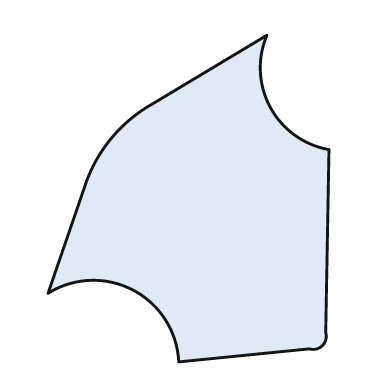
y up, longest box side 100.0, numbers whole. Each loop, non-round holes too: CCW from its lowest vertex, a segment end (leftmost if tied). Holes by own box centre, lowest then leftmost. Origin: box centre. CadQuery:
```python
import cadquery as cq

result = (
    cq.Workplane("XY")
    .moveTo(-3.0, -50.0)
    .lineTo(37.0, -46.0)
    .threePointArc((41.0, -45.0), (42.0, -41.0))
    .lineTo(43.0, 15.0)
    .threePointArc((25.0, 28.0), (24.0, 50.0))
    .lineTo(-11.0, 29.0)
    .threePointArc((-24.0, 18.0), (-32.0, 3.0))
    .lineTo(-43.0, -29.0)
    .threePointArc((-17.0, -28.0), (-3.0, -50.0))
    .close()
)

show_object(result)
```